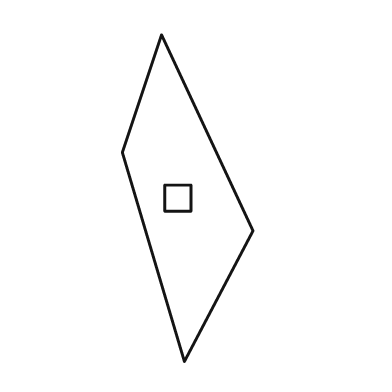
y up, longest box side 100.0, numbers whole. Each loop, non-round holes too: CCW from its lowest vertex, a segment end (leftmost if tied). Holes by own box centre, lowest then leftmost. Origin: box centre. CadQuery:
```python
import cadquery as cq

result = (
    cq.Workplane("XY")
    .moveTo(-1.0, -50.0)
    .lineTo(20.0, -10.0)
    .lineTo(-8.0, 50.0)
    .lineTo(-20.0, 14.0)
    .close()
    .moveTo(-7.0, -4.0)
    .lineTo(1.0, -4.0)
    .lineTo(1.0, 4.0)
    .lineTo(-7.0, 4.0)
    .close()
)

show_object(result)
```